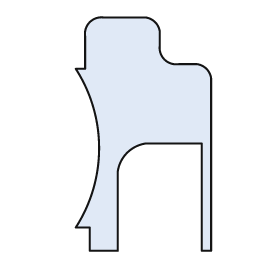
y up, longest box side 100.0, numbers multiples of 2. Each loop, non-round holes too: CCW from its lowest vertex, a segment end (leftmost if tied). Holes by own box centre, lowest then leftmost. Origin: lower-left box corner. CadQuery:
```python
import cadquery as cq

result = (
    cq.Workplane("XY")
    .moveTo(6.0, 0.0)
    .lineTo(18.0, 0.0)
    .lineTo(18.0, 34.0)
    .threePointArc((22.0, 42.0), (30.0, 46.0))
    .lineTo(54.0, 46.0)
    .lineTo(54.0, 0.0)
    .lineTo(58.0, 0.0)
    .lineTo(58.0, 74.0)
    .threePointArc((56.0, 78.0), (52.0, 80.0))
    .lineTo(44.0, 80.0)
    .threePointArc((38.0, 82.0), (36.0, 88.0))
    .lineTo(36.0, 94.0)
    .threePointArc((34.0, 98.0), (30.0, 100.0))
    .lineTo(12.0, 100.0)
    .threePointArc((6.0, 98.0), (4.0, 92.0))
    .lineTo(4.0, 78.0)
    .lineTo(0.0, 78.0)
    .threePointArc((10.0, 44.0), (0.0, 10.0))
    .lineTo(6.0, 10.0)
    .close()
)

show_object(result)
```